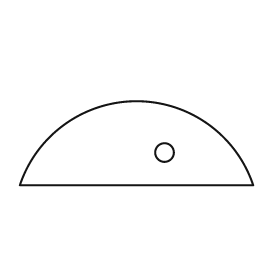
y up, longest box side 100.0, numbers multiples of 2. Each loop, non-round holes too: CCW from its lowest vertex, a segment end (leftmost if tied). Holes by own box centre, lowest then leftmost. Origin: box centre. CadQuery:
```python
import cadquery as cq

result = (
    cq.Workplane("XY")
    .moveTo(-50.0, -18.0)
    .lineTo(50.0, -18.0)
    .threePointArc((0.0, 18.0), (-50.0, -18.0))
    .close()
    .moveTo(12.0, -4.0)
    .circle(4.0)
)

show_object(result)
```